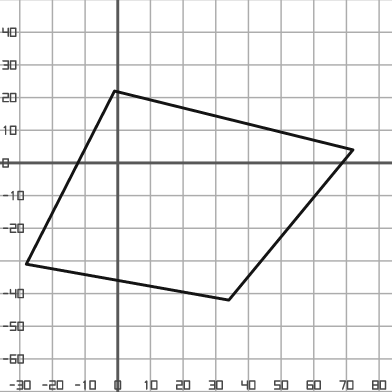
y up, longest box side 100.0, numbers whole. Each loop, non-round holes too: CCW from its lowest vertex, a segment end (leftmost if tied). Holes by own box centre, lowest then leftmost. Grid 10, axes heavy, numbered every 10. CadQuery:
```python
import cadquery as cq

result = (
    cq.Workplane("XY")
    .moveTo(34.0, -42.0)
    .lineTo(72.0, 4.0)
    .lineTo(-1.0, 22.0)
    .lineTo(-28.0, -31.0)
    .close()
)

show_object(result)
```